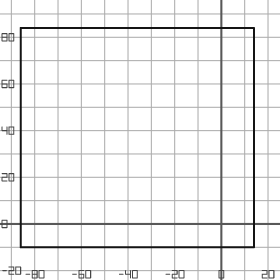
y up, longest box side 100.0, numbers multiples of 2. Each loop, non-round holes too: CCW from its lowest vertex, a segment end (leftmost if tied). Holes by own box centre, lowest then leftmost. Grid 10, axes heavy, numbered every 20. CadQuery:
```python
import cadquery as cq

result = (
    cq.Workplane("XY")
    .moveTo(-86.0, -10.0)
    .lineTo(14.0, -10.0)
    .lineTo(14.0, 84.0)
    .lineTo(-86.0, 84.0)
    .close()
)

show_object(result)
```